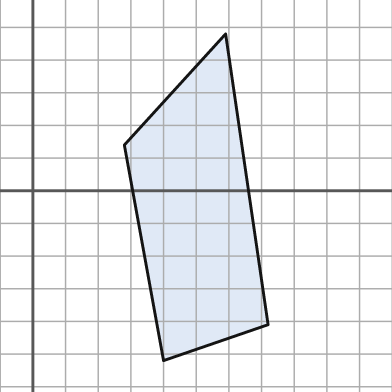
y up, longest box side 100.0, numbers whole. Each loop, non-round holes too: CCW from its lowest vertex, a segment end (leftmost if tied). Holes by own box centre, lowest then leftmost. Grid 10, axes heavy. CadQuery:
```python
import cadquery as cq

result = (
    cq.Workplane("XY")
    .moveTo(40.0, -52.0)
    .lineTo(72.0, -41.0)
    .lineTo(59.0, 48.0)
    .lineTo(28.0, 14.0)
    .close()
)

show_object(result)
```